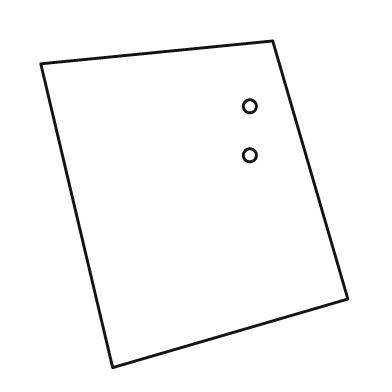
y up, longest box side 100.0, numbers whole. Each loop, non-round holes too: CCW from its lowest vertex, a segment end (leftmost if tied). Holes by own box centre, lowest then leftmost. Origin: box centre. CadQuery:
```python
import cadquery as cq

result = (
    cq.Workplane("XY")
    .moveTo(-25.0, -50.0)
    .lineTo(47.0, -29.0)
    .lineTo(24.0, 50.0)
    .lineTo(-47.0, 43.0)
    .close()
    .moveTo(17.0, 15.0)
    .circle(2.0)
    .moveTo(17.0, 30.0)
    .circle(2.0)
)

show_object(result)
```